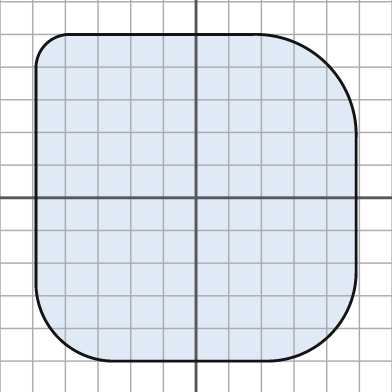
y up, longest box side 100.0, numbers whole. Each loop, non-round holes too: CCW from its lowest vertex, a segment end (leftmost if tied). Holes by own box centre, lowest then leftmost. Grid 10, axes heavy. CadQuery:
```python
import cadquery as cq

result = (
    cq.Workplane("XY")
    .moveTo(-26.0, -50.0)
    .lineTo(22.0, -50.0)
    .threePointArc((41.0, -42.0), (49.0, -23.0))
    .lineTo(49.0, 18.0)
    .threePointArc((40.0, 41.0), (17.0, 50.0))
    .lineTo(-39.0, 50.0)
    .threePointArc((-46.0, 47.0), (-49.0, 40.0))
    .lineTo(-49.0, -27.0)
    .threePointArc((-42.0, -43.0), (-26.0, -50.0))
    .close()
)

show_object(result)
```